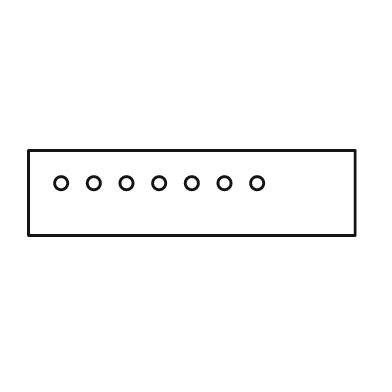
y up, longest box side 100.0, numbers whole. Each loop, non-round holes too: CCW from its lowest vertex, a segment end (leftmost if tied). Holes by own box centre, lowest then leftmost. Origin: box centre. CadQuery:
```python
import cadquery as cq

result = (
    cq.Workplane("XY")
    .moveTo(-50.0, -13.0)
    .lineTo(50.0, -13.0)
    .lineTo(50.0, 13.0)
    .lineTo(-50.0, 13.0)
    .close()
    .moveTo(-40.0, 3.0)
    .circle(2.0)
    .moveTo(-30.0, 3.0)
    .circle(2.0)
    .moveTo(-20.0, 3.0)
    .circle(2.0)
    .moveTo(-10.0, 3.0)
    .circle(2.0)
    .moveTo(0.0, 3.0)
    .circle(2.0)
    .moveTo(10.0, 3.0)
    .circle(2.0)
    .moveTo(20.0, 3.0)
    .circle(2.0)
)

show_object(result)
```